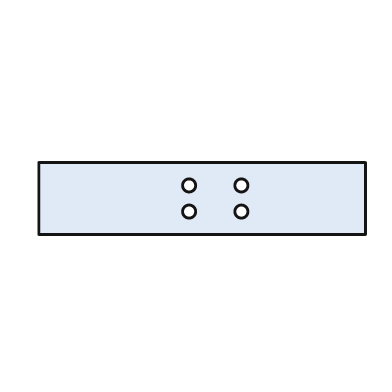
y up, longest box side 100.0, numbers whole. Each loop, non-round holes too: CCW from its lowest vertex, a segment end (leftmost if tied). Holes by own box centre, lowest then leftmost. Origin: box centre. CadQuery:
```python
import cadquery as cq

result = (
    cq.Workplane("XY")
    .moveTo(-50.0, -11.0)
    .lineTo(50.0, -11.0)
    .lineTo(50.0, 11.0)
    .lineTo(-50.0, 11.0)
    .close()
    .moveTo(-4.0, -4.0)
    .circle(2.0)
    .moveTo(12.0, -4.0)
    .circle(2.0)
    .moveTo(-4.0, 4.0)
    .circle(2.0)
    .moveTo(12.0, 4.0)
    .circle(2.0)
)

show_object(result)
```